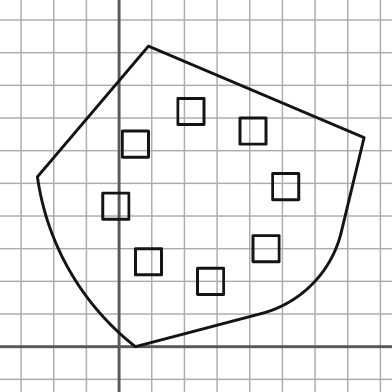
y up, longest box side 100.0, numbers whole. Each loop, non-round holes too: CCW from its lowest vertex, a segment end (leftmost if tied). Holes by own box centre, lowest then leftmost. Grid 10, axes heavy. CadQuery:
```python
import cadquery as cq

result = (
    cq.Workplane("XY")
    .moveTo(5.0, 0.0)
    .lineTo(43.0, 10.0)
    .threePointArc((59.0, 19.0), (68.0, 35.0))
    .lineTo(75.0, 64.0)
    .lineTo(9.0, 92.0)
    .lineTo(-25.0, 52.0)
    .threePointArc((-15.0, 23.0), (5.0, 0.0))
    .close()
    .moveTo(24.0, 16.0)
    .lineTo(32.0, 16.0)
    .lineTo(32.0, 24.0)
    .lineTo(24.0, 24.0)
    .close()
    .moveTo(5.0, 22.0)
    .lineTo(13.0, 22.0)
    .lineTo(13.0, 30.0)
    .lineTo(5.0, 30.0)
    .close()
    .moveTo(41.0, 26.0)
    .lineTo(49.0, 26.0)
    .lineTo(49.0, 34.0)
    .lineTo(41.0, 34.0)
    .close()
    .moveTo(-5.0, 39.0)
    .lineTo(3.0, 39.0)
    .lineTo(3.0, 47.0)
    .lineTo(-5.0, 47.0)
    .close()
    .moveTo(47.0, 45.0)
    .lineTo(55.0, 45.0)
    .lineTo(55.0, 53.0)
    .lineTo(47.0, 53.0)
    .close()
    .moveTo(1.0, 58.0)
    .lineTo(9.0, 58.0)
    .lineTo(9.0, 66.0)
    .lineTo(1.0, 66.0)
    .close()
    .moveTo(37.0, 62.0)
    .lineTo(45.0, 62.0)
    .lineTo(45.0, 70.0)
    .lineTo(37.0, 70.0)
    .close()
    .moveTo(18.0, 68.0)
    .lineTo(26.0, 68.0)
    .lineTo(26.0, 76.0)
    .lineTo(18.0, 76.0)
    .close()
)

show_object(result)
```